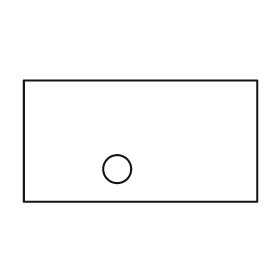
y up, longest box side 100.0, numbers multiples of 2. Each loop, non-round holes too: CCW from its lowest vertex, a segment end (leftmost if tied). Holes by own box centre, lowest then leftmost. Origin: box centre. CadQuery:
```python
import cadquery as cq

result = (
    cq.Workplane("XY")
    .moveTo(-50.0, -26.0)
    .lineTo(50.0, -26.0)
    .lineTo(50.0, 26.0)
    .lineTo(-50.0, 26.0)
    .close()
    .moveTo(-10.0, -12.0)
    .circle(6.0)
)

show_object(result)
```